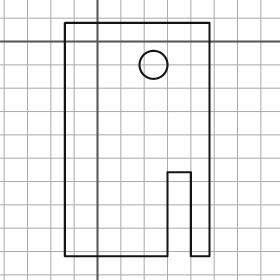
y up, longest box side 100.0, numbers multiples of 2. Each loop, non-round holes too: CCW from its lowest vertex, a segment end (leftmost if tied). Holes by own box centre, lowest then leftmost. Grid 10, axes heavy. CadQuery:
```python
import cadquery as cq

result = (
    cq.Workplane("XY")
    .moveTo(-14.0, -92.0)
    .lineTo(30.0, -92.0)
    .lineTo(30.0, -56.0)
    .lineTo(40.0, -56.0)
    .lineTo(40.0, -92.0)
    .lineTo(48.0, -92.0)
    .lineTo(48.0, 8.0)
    .lineTo(-14.0, 8.0)
    .close()
    .moveTo(24.0, -10.0)
    .circle(6.0)
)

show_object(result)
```